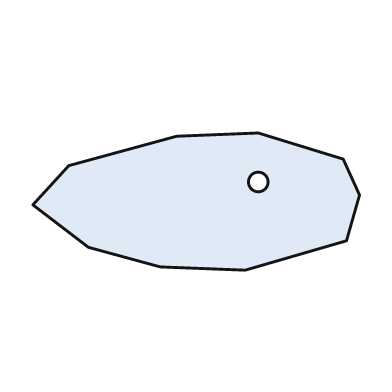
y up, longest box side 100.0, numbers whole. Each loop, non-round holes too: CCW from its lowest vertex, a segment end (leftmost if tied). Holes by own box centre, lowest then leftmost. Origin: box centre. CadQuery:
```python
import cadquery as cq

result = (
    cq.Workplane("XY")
    .moveTo(15.0, -21.0)
    .lineTo(46.0, -12.0)
    .lineTo(50.0, 2.0)
    .lineTo(45.0, 13.0)
    .lineTo(19.0, 21.0)
    .lineTo(-6.0, 20.0)
    .lineTo(-39.0, 11.0)
    .lineTo(-50.0, -1.0)
    .lineTo(-33.0, -14.0)
    .lineTo(-11.0, -20.0)
    .close()
    .moveTo(19.0, 6.0)
    .circle(3.0)
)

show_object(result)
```